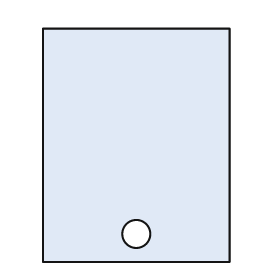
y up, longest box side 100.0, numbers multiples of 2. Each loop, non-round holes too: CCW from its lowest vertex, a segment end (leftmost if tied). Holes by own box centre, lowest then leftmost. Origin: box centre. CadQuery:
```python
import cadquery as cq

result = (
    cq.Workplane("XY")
    .moveTo(-40.0, -50.0)
    .lineTo(40.0, -50.0)
    .lineTo(40.0, 50.0)
    .lineTo(-40.0, 50.0)
    .close()
    .moveTo(0.0, -38.0)
    .circle(6.0)
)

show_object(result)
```